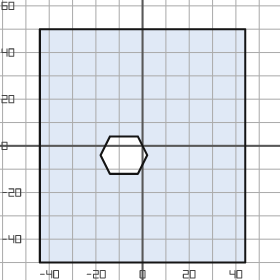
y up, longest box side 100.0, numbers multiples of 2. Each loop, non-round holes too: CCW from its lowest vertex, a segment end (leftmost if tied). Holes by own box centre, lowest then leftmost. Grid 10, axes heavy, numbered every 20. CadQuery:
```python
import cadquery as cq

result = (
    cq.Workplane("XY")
    .moveTo(-44.0, -50.0)
    .lineTo(44.0, -50.0)
    .lineTo(44.0, 50.0)
    .lineTo(-44.0, 50.0)
    .close()
    .moveTo(-14.0, -12.0)
    .lineTo(-2.0, -12.0)
    .lineTo(2.0, -4.0)
    .lineTo(-2.0, 4.0)
    .lineTo(-14.0, 4.0)
    .lineTo(-18.0, -4.0)
    .close()
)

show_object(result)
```